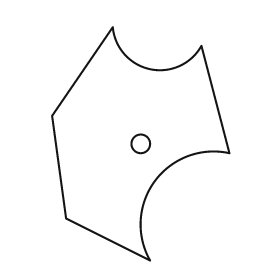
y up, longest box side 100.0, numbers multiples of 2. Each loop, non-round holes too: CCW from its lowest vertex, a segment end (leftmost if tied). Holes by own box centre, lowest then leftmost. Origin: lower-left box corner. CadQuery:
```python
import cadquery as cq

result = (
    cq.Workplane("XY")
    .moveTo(42.0, 0.0)
    .threePointArc((44.0, 34.0), (76.0, 46.0))
    .lineTo(64.0, 92.0)
    .threePointArc((42.0, 82.0), (26.0, 100.0))
    .lineTo(0.0, 62.0)
    .lineTo(6.0, 18.0)
    .close()
    .moveTo(38.0, 50.0)
    .circle(4.0)
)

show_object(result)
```